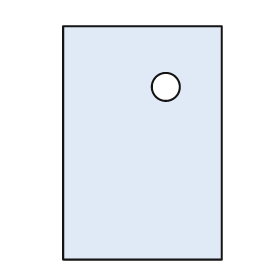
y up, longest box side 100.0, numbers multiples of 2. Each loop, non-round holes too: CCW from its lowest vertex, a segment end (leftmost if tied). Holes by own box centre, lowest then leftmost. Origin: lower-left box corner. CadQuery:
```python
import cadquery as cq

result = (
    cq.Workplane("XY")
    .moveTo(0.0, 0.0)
    .lineTo(68.0, 0.0)
    .lineTo(68.0, 100.0)
    .lineTo(0.0, 100.0)
    .close()
    .moveTo(44.0, 74.0)
    .circle(6.0)
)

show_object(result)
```